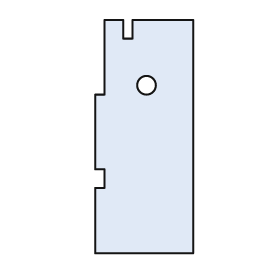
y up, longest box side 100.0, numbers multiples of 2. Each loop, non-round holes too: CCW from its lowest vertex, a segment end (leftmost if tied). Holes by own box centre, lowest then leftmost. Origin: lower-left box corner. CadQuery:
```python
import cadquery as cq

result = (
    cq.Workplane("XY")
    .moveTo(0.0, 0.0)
    .lineTo(42.0, 0.0)
    .lineTo(42.0, 100.0)
    .lineTo(16.0, 100.0)
    .lineTo(16.0, 92.0)
    .lineTo(12.0, 92.0)
    .lineTo(12.0, 100.0)
    .lineTo(4.0, 100.0)
    .lineTo(4.0, 68.0)
    .lineTo(0.0, 68.0)
    .lineTo(0.0, 36.0)
    .lineTo(4.0, 36.0)
    .lineTo(4.0, 28.0)
    .lineTo(0.0, 28.0)
    .close()
    .moveTo(22.0, 72.0)
    .circle(4.0)
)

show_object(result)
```